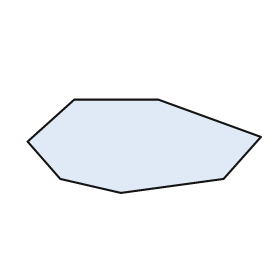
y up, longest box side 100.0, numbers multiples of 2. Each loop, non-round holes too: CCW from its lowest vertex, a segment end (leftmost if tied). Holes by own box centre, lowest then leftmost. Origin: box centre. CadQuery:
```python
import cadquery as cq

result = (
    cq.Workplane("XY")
    .moveTo(-10.0, -20.0)
    .lineTo(34.0, -14.0)
    .lineTo(50.0, 4.0)
    .lineTo(6.0, 20.0)
    .lineTo(-30.0, 20.0)
    .lineTo(-50.0, 2.0)
    .lineTo(-36.0, -14.0)
    .close()
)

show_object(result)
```